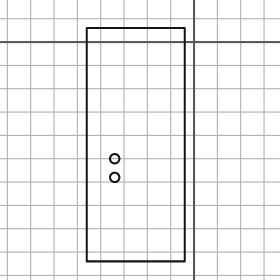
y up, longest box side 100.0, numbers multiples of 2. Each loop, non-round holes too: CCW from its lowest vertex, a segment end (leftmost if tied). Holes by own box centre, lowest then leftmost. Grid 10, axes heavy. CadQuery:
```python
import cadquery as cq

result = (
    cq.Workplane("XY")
    .moveTo(-46.0, -94.0)
    .lineTo(-4.0, -94.0)
    .lineTo(-4.0, 6.0)
    .lineTo(-46.0, 6.0)
    .close()
    .moveTo(-34.0, -58.0)
    .circle(2.0)
    .moveTo(-34.0, -50.0)
    .circle(2.0)
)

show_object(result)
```